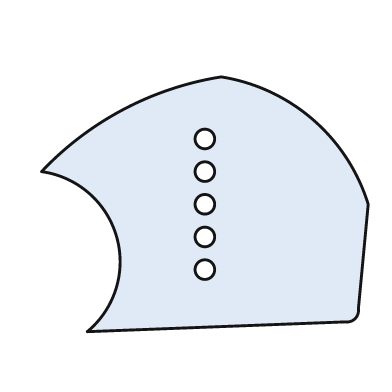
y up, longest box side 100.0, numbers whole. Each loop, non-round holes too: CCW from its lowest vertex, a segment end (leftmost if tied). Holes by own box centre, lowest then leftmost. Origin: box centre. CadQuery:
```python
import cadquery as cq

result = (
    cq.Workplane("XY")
    .moveTo(-36.0, -39.0)
    .lineTo(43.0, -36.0)
    .threePointArc((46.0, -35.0), (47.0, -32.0))
    .lineTo(50.0, 0.0)
    .threePointArc((33.0, 26.0), (5.0, 39.0))
    .threePointArc((-25.0, 29.0), (-50.0, 10.0))
    .threePointArc((-27.0, -10.0), (-36.0, -39.0))
    .close()
    .moveTo(0.0, -20.0)
    .circle(3.0)
    .moveTo(0.0, -10.0)
    .circle(3.0)
    .moveTo(0.0, 0.0)
    .circle(3.0)
    .moveTo(0.0, 10.0)
    .circle(3.0)
    .moveTo(0.0, 20.0)
    .circle(3.0)
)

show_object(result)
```